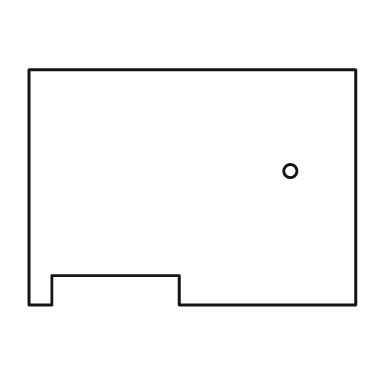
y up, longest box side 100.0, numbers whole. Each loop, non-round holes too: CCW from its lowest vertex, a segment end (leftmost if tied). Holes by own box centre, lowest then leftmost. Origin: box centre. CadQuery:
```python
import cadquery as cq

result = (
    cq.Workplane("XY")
    .moveTo(-50.0, -36.0)
    .lineTo(-43.0, -36.0)
    .lineTo(-43.0, -27.0)
    .lineTo(-4.0, -27.0)
    .lineTo(-4.0, -36.0)
    .lineTo(50.0, -36.0)
    .lineTo(50.0, 36.0)
    .lineTo(-50.0, 36.0)
    .close()
    .moveTo(30.0, 5.0)
    .circle(2.0)
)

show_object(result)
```